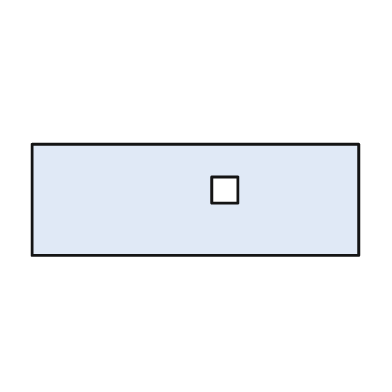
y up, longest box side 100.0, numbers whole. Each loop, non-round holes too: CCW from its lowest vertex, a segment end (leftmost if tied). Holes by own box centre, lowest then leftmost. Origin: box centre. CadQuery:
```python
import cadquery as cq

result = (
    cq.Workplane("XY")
    .moveTo(-50.0, -17.0)
    .lineTo(50.0, -17.0)
    .lineTo(50.0, 17.0)
    .lineTo(-50.0, 17.0)
    .close()
    .moveTo(5.0, -1.0)
    .lineTo(13.0, -1.0)
    .lineTo(13.0, 7.0)
    .lineTo(5.0, 7.0)
    .close()
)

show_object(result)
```